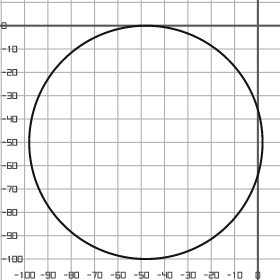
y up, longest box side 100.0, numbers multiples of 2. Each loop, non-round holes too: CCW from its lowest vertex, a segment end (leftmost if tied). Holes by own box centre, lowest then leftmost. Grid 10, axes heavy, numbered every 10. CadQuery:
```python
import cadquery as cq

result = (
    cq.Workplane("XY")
    .moveTo(-48.0, -50.0)
    .circle(50.0)
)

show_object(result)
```